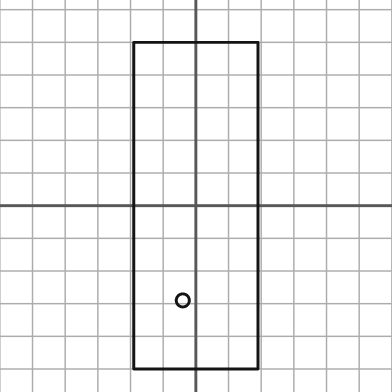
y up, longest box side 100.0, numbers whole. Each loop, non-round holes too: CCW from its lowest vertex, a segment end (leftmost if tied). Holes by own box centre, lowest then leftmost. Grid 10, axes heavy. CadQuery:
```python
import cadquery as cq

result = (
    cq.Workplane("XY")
    .moveTo(-19.0, -50.0)
    .lineTo(19.0, -50.0)
    .lineTo(19.0, 50.0)
    .lineTo(-19.0, 50.0)
    .close()
    .moveTo(-4.0, -29.0)
    .circle(2.0)
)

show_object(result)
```